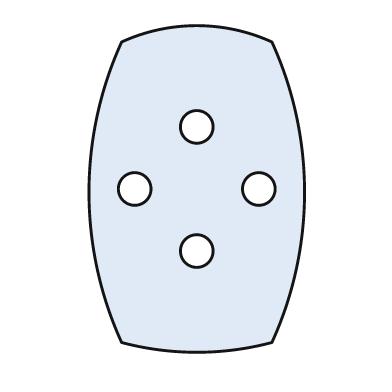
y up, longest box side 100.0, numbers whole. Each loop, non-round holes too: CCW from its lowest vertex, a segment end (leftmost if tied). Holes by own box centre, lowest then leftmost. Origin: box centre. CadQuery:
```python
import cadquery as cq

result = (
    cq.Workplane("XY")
    .moveTo(-23.0, -47.0)
    .threePointArc((0.0, -50.0), (23.0, -47.0))
    .threePointArc((33.0, -1.0), (23.0, 45.0))
    .threePointArc((0.0, 50.0), (-23.0, 45.0))
    .threePointArc((-33.0, -1.0), (-23.0, -47.0))
    .close()
    .moveTo(0.0, -19.0)
    .circle(5.0)
    .moveTo(-19.0, 0.0)
    .circle(5.0)
    .moveTo(19.0, 0.0)
    .circle(5.0)
    .moveTo(0.0, 19.0)
    .circle(5.0)
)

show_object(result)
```